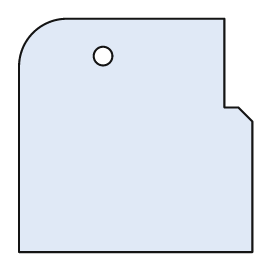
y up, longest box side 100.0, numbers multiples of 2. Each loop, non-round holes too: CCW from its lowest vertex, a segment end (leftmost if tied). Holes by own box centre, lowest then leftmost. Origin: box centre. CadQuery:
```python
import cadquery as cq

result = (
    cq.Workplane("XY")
    .moveTo(-50.0, -50.0)
    .lineTo(50.0, -50.0)
    .lineTo(50.0, 6.0)
    .lineTo(44.0, 12.0)
    .lineTo(38.0, 12.0)
    .lineTo(38.0, 50.0)
    .lineTo(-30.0, 50.0)
    .threePointArc((-44.0, 44.0), (-50.0, 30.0))
    .close()
    .moveTo(-14.0, 34.0)
    .circle(4.0)
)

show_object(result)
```